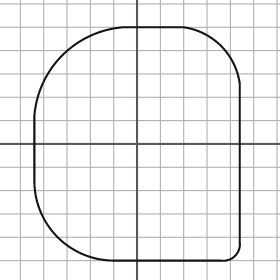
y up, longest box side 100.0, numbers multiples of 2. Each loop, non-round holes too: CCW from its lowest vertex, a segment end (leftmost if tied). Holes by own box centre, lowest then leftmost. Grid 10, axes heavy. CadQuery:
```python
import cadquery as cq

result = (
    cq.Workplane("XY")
    .moveTo(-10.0, -50.0)
    .lineTo(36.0, -50.0)
    .threePointArc((42.0, -48.0), (44.0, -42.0))
    .lineTo(44.0, 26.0)
    .threePointArc((36.0, 42.0), (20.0, 50.0))
    .lineTo(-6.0, 50.0)
    .threePointArc((-32.0, 38.0), (-44.0, 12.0))
    .lineTo(-44.0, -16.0)
    .threePointArc((-34.0, -40.0), (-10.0, -50.0))
    .close()
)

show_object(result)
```